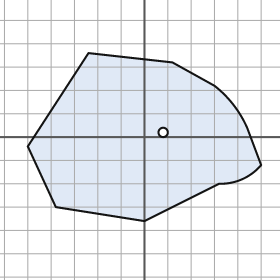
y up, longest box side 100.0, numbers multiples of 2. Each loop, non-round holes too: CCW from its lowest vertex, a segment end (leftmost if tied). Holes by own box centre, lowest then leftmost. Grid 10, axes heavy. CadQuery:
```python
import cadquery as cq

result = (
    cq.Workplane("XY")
    .moveTo(0.0, -36.0)
    .lineTo(32.0, -20.0)
    .threePointArc((42.0, -18.0), (50.0, -12.0))
    .lineTo(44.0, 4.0)
    .threePointArc((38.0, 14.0), (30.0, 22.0))
    .lineTo(12.0, 32.0)
    .lineTo(-24.0, 36.0)
    .lineTo(-50.0, -4.0)
    .lineTo(-38.0, -30.0)
    .close()
    .moveTo(8.0, 2.0)
    .circle(2.0)
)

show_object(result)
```